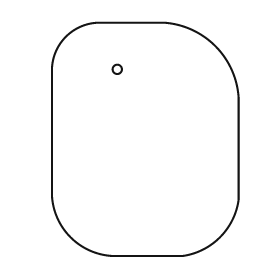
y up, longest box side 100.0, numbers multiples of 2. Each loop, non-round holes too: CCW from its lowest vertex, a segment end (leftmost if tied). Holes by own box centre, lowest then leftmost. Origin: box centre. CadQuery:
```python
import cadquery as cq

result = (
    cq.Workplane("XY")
    .moveTo(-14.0, -50.0)
    .lineTo(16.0, -50.0)
    .threePointArc((32.0, -42.0), (40.0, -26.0))
    .lineTo(40.0, 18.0)
    .threePointArc((30.0, 40.0), (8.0, 50.0))
    .lineTo(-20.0, 50.0)
    .threePointArc((-34.0, 44.0), (-40.0, 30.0))
    .lineTo(-40.0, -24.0)
    .threePointArc((-32.0, -42.0), (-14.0, -50.0))
    .close()
    .moveTo(-12.0, 30.0)
    .circle(2.0)
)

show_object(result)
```